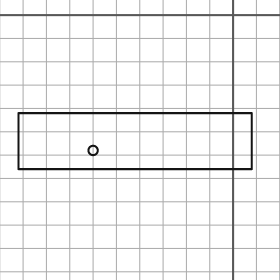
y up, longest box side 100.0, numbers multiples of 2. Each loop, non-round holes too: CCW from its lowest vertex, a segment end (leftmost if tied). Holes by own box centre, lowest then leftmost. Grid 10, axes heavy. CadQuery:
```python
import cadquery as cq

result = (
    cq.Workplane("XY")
    .moveTo(-92.0, -66.0)
    .lineTo(8.0, -66.0)
    .lineTo(8.0, -42.0)
    .lineTo(-92.0, -42.0)
    .close()
    .moveTo(-60.0, -58.0)
    .circle(2.0)
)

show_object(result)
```